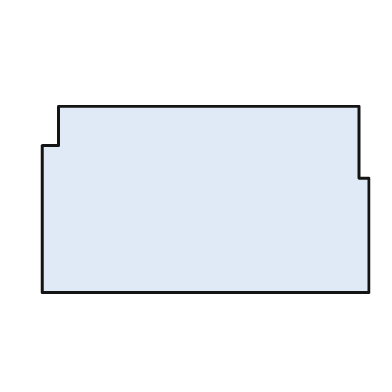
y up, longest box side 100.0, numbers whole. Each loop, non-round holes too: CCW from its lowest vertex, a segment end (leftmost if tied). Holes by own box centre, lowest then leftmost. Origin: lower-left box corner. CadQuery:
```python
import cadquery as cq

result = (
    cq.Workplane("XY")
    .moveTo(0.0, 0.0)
    .lineTo(100.0, 0.0)
    .lineTo(100.0, 35.0)
    .lineTo(97.0, 35.0)
    .lineTo(97.0, 57.0)
    .lineTo(5.0, 57.0)
    .lineTo(5.0, 45.0)
    .lineTo(0.0, 45.0)
    .close()
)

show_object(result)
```